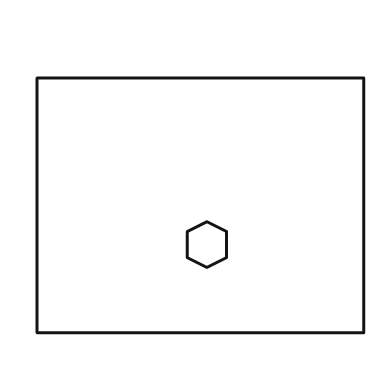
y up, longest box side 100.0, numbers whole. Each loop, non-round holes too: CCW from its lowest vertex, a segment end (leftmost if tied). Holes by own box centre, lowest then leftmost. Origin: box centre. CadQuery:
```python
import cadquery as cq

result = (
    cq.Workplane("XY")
    .moveTo(-50.0, -39.0)
    .lineTo(50.0, -39.0)
    .lineTo(50.0, 39.0)
    .lineTo(-50.0, 39.0)
    .close()
    .moveTo(2.0, -19.0)
    .lineTo(8.0, -16.0)
    .lineTo(8.0, -8.0)
    .lineTo(2.0, -5.0)
    .lineTo(-4.0, -8.0)
    .lineTo(-4.0, -16.0)
    .close()
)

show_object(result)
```